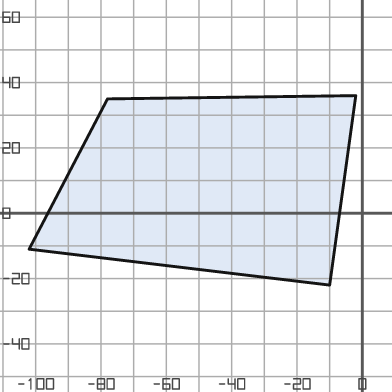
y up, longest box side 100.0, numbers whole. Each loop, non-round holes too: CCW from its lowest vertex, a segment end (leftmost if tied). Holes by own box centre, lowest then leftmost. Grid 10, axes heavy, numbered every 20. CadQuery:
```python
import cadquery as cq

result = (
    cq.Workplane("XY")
    .moveTo(-10.0, -22.0)
    .lineTo(-2.0, 36.0)
    .lineTo(-78.0, 35.0)
    .lineTo(-102.0, -11.0)
    .close()
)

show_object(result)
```